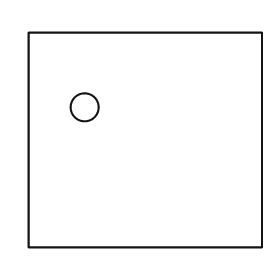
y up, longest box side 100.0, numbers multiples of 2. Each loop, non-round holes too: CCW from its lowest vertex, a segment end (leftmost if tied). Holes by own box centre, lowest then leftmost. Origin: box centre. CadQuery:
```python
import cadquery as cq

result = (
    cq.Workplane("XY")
    .moveTo(-50.0, -46.0)
    .lineTo(50.0, -46.0)
    .lineTo(50.0, 46.0)
    .lineTo(-50.0, 46.0)
    .close()
    .moveTo(-26.0, 14.0)
    .circle(6.0)
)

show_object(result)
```